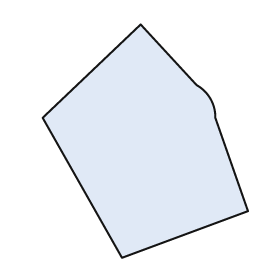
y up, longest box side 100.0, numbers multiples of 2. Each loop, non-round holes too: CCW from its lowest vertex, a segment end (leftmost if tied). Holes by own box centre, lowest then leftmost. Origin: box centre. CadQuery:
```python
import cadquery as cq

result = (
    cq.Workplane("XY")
    .moveTo(-10.0, -50.0)
    .lineTo(44.0, -30.0)
    .lineTo(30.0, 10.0)
    .threePointArc((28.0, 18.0), (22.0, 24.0))
    .lineTo(-2.0, 50.0)
    .lineTo(-44.0, 10.0)
    .close()
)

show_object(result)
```